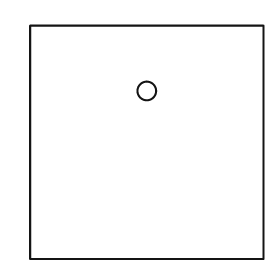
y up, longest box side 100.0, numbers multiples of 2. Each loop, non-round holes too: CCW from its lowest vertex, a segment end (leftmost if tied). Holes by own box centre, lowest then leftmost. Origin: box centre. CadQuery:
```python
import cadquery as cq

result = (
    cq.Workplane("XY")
    .moveTo(-50.0, -50.0)
    .lineTo(50.0, -50.0)
    .lineTo(50.0, 50.0)
    .lineTo(-50.0, 50.0)
    .close()
    .moveTo(0.0, 22.0)
    .circle(4.0)
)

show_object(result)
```